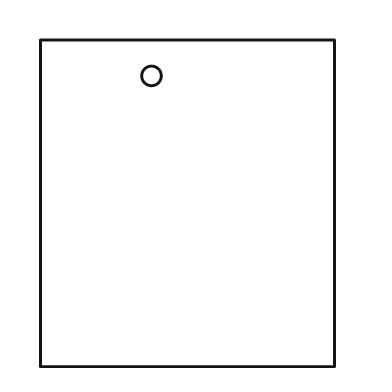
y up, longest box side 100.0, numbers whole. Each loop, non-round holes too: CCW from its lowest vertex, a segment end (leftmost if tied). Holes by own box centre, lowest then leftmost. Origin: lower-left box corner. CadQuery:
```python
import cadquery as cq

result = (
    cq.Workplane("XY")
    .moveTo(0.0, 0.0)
    .lineTo(90.0, 0.0)
    .lineTo(90.0, 100.0)
    .lineTo(0.0, 100.0)
    .close()
    .moveTo(34.0, 89.0)
    .circle(3.0)
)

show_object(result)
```